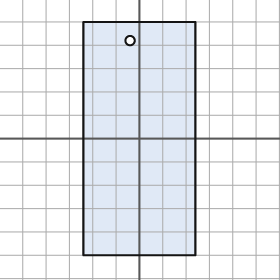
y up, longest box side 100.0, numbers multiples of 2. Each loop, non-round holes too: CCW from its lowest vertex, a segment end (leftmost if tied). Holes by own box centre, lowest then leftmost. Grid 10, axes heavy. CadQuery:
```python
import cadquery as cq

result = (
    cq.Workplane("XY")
    .moveTo(-24.0, -50.0)
    .lineTo(24.0, -50.0)
    .lineTo(24.0, 50.0)
    .lineTo(-24.0, 50.0)
    .close()
    .moveTo(-4.0, 42.0)
    .circle(2.0)
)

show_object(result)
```